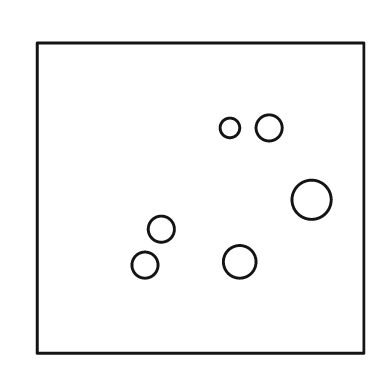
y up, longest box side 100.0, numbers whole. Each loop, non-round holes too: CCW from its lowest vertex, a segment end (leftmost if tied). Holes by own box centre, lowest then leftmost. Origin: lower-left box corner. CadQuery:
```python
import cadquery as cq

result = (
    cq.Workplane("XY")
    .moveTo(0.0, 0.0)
    .lineTo(100.0, 0.0)
    .lineTo(100.0, 95.0)
    .lineTo(0.0, 95.0)
    .close()
    .moveTo(33.0, 27.0)
    .circle(4.0)
    .moveTo(62.0, 28.0)
    .circle(5.0)
    .moveTo(38.0, 38.0)
    .circle(4.0)
    .moveTo(84.0, 47.0)
    .circle(6.0)
    .moveTo(59.0, 69.0)
    .circle(3.0)
    .moveTo(71.0, 69.0)
    .circle(4.0)
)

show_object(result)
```